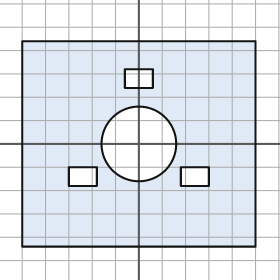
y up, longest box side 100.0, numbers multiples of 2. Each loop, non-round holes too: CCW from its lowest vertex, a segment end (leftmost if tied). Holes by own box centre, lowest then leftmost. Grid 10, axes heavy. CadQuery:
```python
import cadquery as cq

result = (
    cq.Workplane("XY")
    .moveTo(-50.0, -44.0)
    .lineTo(50.0, -44.0)
    .lineTo(50.0, 44.0)
    .lineTo(-50.0, 44.0)
    .close()
    .moveTo(-30.0, -18.0)
    .lineTo(-18.0, -18.0)
    .lineTo(-18.0, -10.0)
    .lineTo(-30.0, -10.0)
    .close()
    .moveTo(18.0, -18.0)
    .lineTo(30.0, -18.0)
    .lineTo(30.0, -10.0)
    .lineTo(18.0, -10.0)
    .close()
    .moveTo(0.0, 0.0)
    .circle(16.0)
    .moveTo(-6.0, 24.0)
    .lineTo(6.0, 24.0)
    .lineTo(6.0, 32.0)
    .lineTo(-6.0, 32.0)
    .close()
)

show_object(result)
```